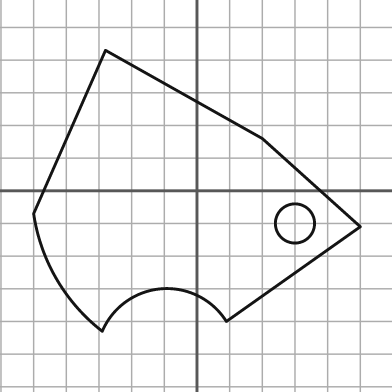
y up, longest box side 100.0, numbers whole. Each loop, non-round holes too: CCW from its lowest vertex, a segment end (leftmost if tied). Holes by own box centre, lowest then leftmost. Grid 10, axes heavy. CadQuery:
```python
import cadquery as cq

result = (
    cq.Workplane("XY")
    .moveTo(-29.0, -43.0)
    .threePointArc((-11.0, -30.0), (9.0, -40.0))
    .lineTo(50.0, -11.0)
    .lineTo(20.0, 16.0)
    .lineTo(-28.0, 43.0)
    .lineTo(-50.0, -7.0)
    .threePointArc((-43.0, -27.0), (-29.0, -43.0))
    .close()
    .moveTo(30.0, -10.0)
    .circle(6.0)
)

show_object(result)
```